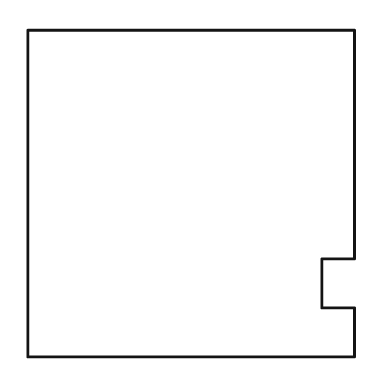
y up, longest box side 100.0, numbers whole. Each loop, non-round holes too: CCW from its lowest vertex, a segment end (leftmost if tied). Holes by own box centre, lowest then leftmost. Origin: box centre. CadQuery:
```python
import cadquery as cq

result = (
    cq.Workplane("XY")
    .moveTo(-50.0, -50.0)
    .lineTo(50.0, -50.0)
    .lineTo(50.0, -35.0)
    .lineTo(40.0, -35.0)
    .lineTo(40.0, -20.0)
    .lineTo(50.0, -20.0)
    .lineTo(50.0, 50.0)
    .lineTo(-50.0, 50.0)
    .close()
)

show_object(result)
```